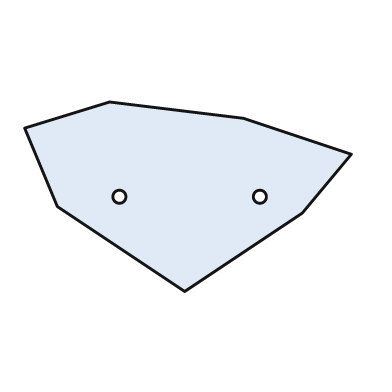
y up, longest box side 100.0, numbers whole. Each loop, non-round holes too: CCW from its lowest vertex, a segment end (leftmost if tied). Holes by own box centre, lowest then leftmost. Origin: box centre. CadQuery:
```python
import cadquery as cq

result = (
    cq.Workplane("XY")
    .moveTo(-1.0, -29.0)
    .lineTo(35.0, -5.0)
    .lineTo(50.0, 13.0)
    .lineTo(17.0, 24.0)
    .lineTo(-24.0, 29.0)
    .lineTo(-50.0, 21.0)
    .lineTo(-40.0, -3.0)
    .close()
    .moveTo(-21.0, 0.0)
    .circle(2.0)
    .moveTo(22.0, 0.0)
    .circle(2.0)
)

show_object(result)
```